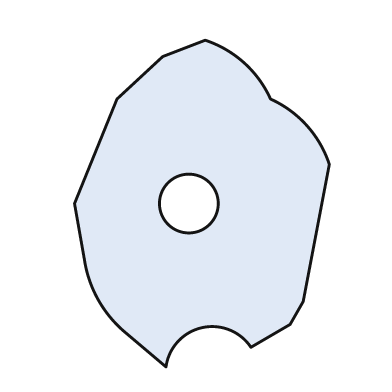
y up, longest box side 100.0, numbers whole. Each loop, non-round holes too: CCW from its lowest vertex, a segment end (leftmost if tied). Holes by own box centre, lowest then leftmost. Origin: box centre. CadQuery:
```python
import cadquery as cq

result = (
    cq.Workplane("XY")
    .moveTo(-11.0, -50.0)
    .threePointArc((0.0, -38.0), (15.0, -44.0))
    .lineTo(27.0, -37.0)
    .lineTo(31.0, -30.0)
    .lineTo(39.0, 12.0)
    .threePointArc((32.0, 24.0), (21.0, 32.0))
    .threePointArc((13.0, 43.0), (1.0, 50.0))
    .lineTo(-12.0, 45.0)
    .lineTo(-26.0, 32.0)
    .lineTo(-39.0, 0.0)
    .lineTo(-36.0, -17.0)
    .threePointArc((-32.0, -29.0), (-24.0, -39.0))
    .close()
    .moveTo(-4.0, 0.0)
    .circle(9.0)
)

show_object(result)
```